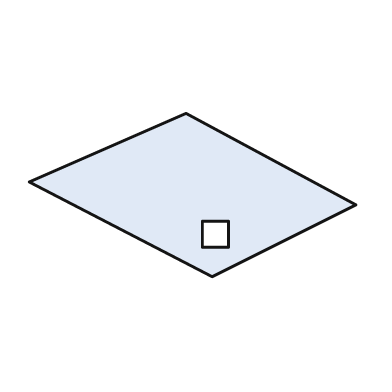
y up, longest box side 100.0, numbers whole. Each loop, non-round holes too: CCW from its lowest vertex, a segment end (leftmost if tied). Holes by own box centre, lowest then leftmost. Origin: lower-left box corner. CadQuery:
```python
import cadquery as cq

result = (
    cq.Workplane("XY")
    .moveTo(56.0, 0.0)
    .lineTo(100.0, 22.0)
    .lineTo(48.0, 50.0)
    .lineTo(0.0, 29.0)
    .close()
    .moveTo(53.0, 9.0)
    .lineTo(61.0, 9.0)
    .lineTo(61.0, 17.0)
    .lineTo(53.0, 17.0)
    .close()
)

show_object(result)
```